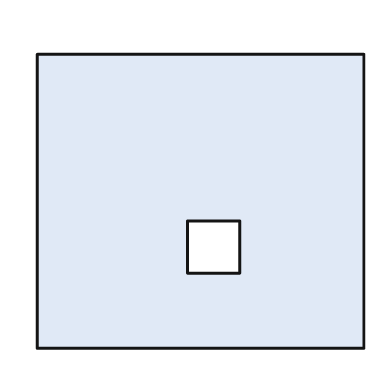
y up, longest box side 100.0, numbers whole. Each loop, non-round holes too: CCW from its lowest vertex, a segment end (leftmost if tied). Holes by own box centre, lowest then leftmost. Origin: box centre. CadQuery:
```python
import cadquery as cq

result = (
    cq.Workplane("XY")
    .moveTo(-50.0, -45.0)
    .lineTo(50.0, -45.0)
    .lineTo(50.0, 45.0)
    .lineTo(-50.0, 45.0)
    .close()
    .moveTo(-4.0, -22.0)
    .lineTo(12.0, -22.0)
    .lineTo(12.0, -6.0)
    .lineTo(-4.0, -6.0)
    .close()
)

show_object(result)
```